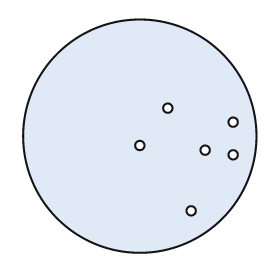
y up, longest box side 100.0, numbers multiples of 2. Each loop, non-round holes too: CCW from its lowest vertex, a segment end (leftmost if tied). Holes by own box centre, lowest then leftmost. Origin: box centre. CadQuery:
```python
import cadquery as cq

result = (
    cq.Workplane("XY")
    .moveTo(0.0, 0.0)
    .circle(50.0)
    .moveTo(22.0, -32.0)
    .circle(2.0)
    .moveTo(40.0, -8.0)
    .circle(2.0)
    .moveTo(28.0, -6.0)
    .circle(2.0)
    .moveTo(0.0, -4.0)
    .circle(2.0)
    .moveTo(40.0, 6.0)
    .circle(2.0)
    .moveTo(12.0, 12.0)
    .circle(2.0)
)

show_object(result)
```